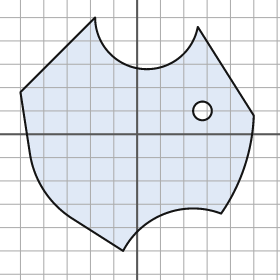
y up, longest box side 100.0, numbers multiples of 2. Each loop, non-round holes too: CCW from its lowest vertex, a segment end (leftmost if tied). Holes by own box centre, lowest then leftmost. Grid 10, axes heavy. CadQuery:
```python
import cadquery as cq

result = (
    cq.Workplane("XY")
    .moveTo(-6.0, -50.0)
    .threePointArc((12.0, -34.0), (36.0, -34.0))
    .threePointArc((46.0, -14.0), (50.0, 8.0))
    .lineTo(26.0, 46.0)
    .threePointArc((2.0, 28.0), (-18.0, 50.0))
    .lineTo(-50.0, 18.0)
    .lineTo(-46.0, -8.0)
    .threePointArc((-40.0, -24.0), (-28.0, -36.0))
    .close()
    .moveTo(28.0, 10.0)
    .circle(4.0)
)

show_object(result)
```